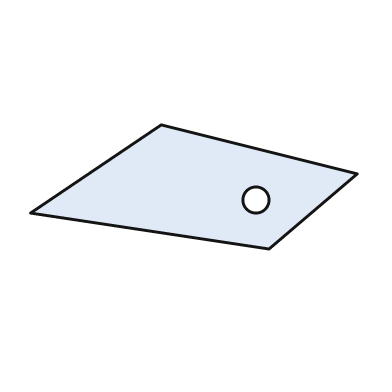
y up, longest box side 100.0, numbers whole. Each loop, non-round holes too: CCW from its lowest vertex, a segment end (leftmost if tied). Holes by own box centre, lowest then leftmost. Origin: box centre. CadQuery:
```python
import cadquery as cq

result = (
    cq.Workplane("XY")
    .moveTo(23.0, -19.0)
    .lineTo(50.0, 4.0)
    .lineTo(-10.0, 19.0)
    .lineTo(-50.0, -8.0)
    .close()
    .moveTo(19.0, -4.0)
    .circle(4.0)
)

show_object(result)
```